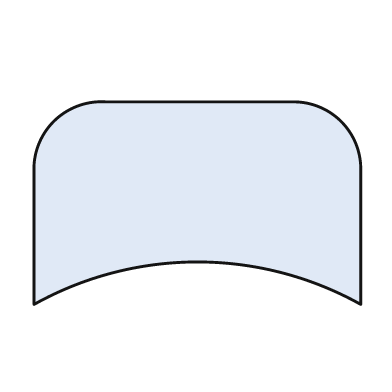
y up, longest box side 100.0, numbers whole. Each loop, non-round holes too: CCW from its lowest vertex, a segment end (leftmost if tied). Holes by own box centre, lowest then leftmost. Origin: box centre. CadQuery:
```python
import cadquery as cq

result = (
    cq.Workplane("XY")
    .moveTo(-50.0, -31.0)
    .threePointArc((0.0, -18.0), (50.0, -31.0))
    .lineTo(50.0, 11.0)
    .threePointArc((44.0, 25.0), (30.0, 31.0))
    .lineTo(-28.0, 31.0)
    .threePointArc((-44.0, 25.0), (-50.0, 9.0))
    .close()
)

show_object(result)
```